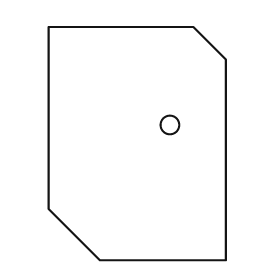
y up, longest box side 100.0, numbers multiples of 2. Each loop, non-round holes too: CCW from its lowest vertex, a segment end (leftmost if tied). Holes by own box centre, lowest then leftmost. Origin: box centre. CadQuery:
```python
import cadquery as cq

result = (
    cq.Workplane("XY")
    .moveTo(-16.0, -50.0)
    .lineTo(38.0, -50.0)
    .lineTo(38.0, 36.0)
    .lineTo(24.0, 50.0)
    .lineTo(-38.0, 50.0)
    .lineTo(-38.0, -28.0)
    .close()
    .moveTo(14.0, 8.0)
    .circle(4.0)
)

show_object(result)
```